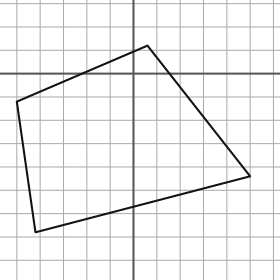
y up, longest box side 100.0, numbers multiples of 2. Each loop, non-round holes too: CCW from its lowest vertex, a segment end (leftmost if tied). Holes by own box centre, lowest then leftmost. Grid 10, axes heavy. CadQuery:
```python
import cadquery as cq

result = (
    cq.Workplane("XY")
    .moveTo(-42.0, -68.0)
    .lineTo(50.0, -44.0)
    .lineTo(6.0, 12.0)
    .lineTo(-50.0, -12.0)
    .close()
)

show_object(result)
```